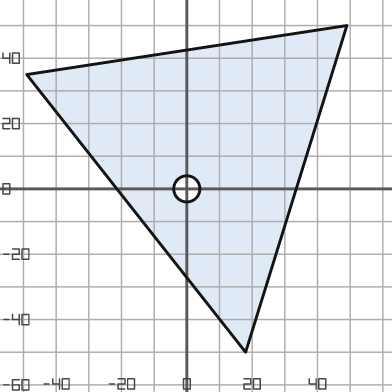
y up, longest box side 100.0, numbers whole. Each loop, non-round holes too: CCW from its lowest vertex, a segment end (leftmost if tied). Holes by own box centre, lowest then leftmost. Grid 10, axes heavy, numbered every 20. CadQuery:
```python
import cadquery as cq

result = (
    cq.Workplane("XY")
    .moveTo(18.0, -50.0)
    .lineTo(49.0, 50.0)
    .lineTo(-49.0, 35.0)
    .close()
    .moveTo(0.0, 0.0)
    .circle(4.0)
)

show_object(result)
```